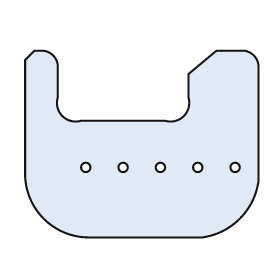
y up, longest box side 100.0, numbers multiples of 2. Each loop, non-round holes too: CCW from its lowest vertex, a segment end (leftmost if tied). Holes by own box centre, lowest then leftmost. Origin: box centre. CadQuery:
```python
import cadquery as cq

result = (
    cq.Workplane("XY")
    .moveTo(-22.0, -40.0)
    .lineTo(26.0, -40.0)
    .threePointArc((42.0, -32.0), (50.0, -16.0))
    .lineTo(50.0, 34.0)
    .threePointArc((48.0, 38.0), (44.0, 40.0))
    .lineTo(32.0, 40.0)
    .lineTo(20.0, 30.0)
    .lineTo(20.0, 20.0)
    .threePointArc((18.0, 12.0), (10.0, 10.0))
    .lineTo(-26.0, 10.0)
    .threePointArc((-34.0, 12.0), (-36.0, 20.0))
    .lineTo(-36.0, 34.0)
    .threePointArc((-38.0, 38.0), (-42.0, 40.0))
    .lineTo(-46.0, 40.0)
    .lineTo(-50.0, 36.0)
    .lineTo(-50.0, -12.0)
    .threePointArc((-42.0, -32.0), (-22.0, -40.0))
    .close()
    .moveTo(-24.0, -10.0)
    .circle(2.0)
    .moveTo(-8.0, -10.0)
    .circle(2.0)
    .moveTo(8.0, -10.0)
    .circle(2.0)
    .moveTo(24.0, -10.0)
    .circle(2.0)
    .moveTo(40.0, -10.0)
    .circle(2.0)
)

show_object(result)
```